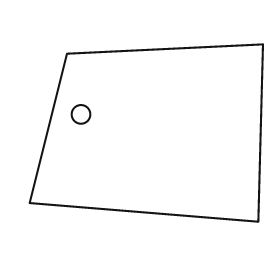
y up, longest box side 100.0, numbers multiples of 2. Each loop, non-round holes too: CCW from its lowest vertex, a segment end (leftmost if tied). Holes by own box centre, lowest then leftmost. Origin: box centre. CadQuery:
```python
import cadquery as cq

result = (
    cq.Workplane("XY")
    .moveTo(48.0, -38.0)
    .lineTo(50.0, 38.0)
    .lineTo(-34.0, 34.0)
    .lineTo(-50.0, -30.0)
    .close()
    .moveTo(-28.0, 8.0)
    .circle(4.0)
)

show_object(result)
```